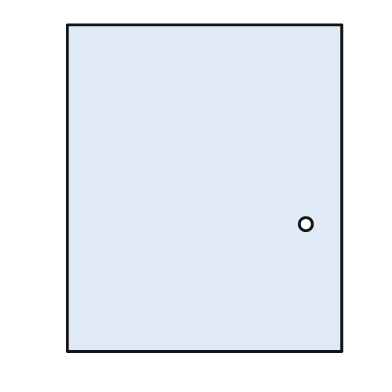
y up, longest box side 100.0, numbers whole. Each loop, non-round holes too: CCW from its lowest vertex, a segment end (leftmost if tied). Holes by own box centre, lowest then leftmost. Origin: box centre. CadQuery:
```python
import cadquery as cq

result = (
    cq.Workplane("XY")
    .moveTo(-42.0, -50.0)
    .lineTo(42.0, -50.0)
    .lineTo(42.0, 50.0)
    .lineTo(-42.0, 50.0)
    .close()
    .moveTo(31.0, -11.0)
    .circle(2.0)
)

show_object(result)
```